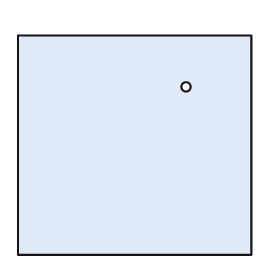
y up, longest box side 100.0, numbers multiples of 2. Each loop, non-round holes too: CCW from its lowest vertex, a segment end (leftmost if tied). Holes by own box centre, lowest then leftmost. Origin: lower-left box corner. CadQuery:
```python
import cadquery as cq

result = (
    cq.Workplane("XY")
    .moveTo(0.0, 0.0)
    .lineTo(100.0, 0.0)
    .lineTo(100.0, 94.0)
    .lineTo(0.0, 94.0)
    .close()
    .moveTo(72.0, 72.0)
    .circle(2.0)
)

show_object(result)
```